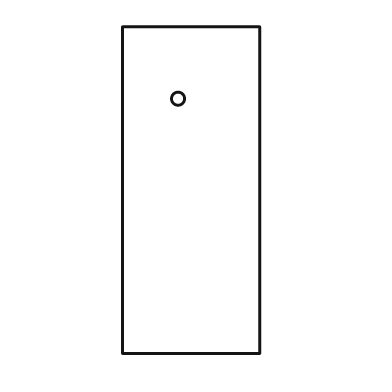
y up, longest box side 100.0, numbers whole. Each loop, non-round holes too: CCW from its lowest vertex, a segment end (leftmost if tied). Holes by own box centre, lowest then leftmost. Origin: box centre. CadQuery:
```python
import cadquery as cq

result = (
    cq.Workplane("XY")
    .moveTo(-21.0, -50.0)
    .lineTo(21.0, -50.0)
    .lineTo(21.0, 50.0)
    .lineTo(-21.0, 50.0)
    .close()
    .moveTo(-4.0, 28.0)
    .circle(2.0)
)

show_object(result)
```